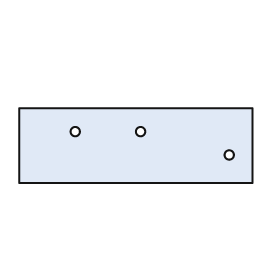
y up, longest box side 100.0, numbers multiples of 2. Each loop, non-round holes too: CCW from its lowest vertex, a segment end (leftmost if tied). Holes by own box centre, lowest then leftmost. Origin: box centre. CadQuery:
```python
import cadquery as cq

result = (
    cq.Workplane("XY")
    .moveTo(-50.0, -16.0)
    .lineTo(50.0, -16.0)
    .lineTo(50.0, 16.0)
    .lineTo(-50.0, 16.0)
    .close()
    .moveTo(40.0, -4.0)
    .circle(2.0)
    .moveTo(-26.0, 6.0)
    .circle(2.0)
    .moveTo(2.0, 6.0)
    .circle(2.0)
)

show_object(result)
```